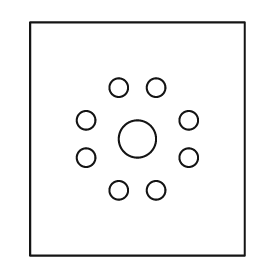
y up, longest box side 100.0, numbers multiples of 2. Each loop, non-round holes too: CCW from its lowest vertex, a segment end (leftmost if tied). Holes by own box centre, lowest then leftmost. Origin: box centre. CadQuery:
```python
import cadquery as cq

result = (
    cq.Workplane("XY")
    .moveTo(-46.0, -50.0)
    .lineTo(46.0, -50.0)
    .lineTo(46.0, 50.0)
    .lineTo(-46.0, 50.0)
    .close()
    .moveTo(-8.0, -22.0)
    .circle(4.0)
    .moveTo(8.0, -22.0)
    .circle(4.0)
    .moveTo(-22.0, -8.0)
    .circle(4.0)
    .moveTo(22.0, -8.0)
    .circle(4.0)
    .moveTo(0.0, 0.0)
    .circle(8.0)
    .moveTo(-22.0, 8.0)
    .circle(4.0)
    .moveTo(22.0, 8.0)
    .circle(4.0)
    .moveTo(-8.0, 22.0)
    .circle(4.0)
    .moveTo(8.0, 22.0)
    .circle(4.0)
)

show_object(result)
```